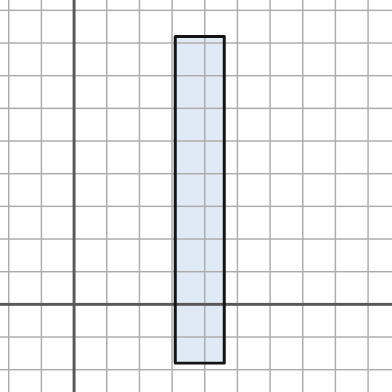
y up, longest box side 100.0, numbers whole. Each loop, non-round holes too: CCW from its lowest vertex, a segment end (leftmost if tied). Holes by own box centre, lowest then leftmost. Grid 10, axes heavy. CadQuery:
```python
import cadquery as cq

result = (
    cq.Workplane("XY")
    .moveTo(31.0, -18.0)
    .lineTo(46.0, -18.0)
    .lineTo(46.0, 82.0)
    .lineTo(31.0, 82.0)
    .close()
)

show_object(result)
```